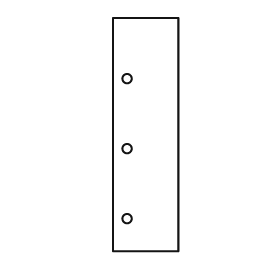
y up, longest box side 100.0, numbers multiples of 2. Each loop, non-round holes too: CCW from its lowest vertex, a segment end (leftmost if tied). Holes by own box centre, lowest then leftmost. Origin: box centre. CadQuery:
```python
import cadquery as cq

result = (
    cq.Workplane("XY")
    .moveTo(-14.0, -50.0)
    .lineTo(14.0, -50.0)
    .lineTo(14.0, 50.0)
    .lineTo(-14.0, 50.0)
    .close()
    .moveTo(-8.0, -36.0)
    .circle(2.0)
    .moveTo(-8.0, -6.0)
    .circle(2.0)
    .moveTo(-8.0, 24.0)
    .circle(2.0)
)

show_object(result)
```